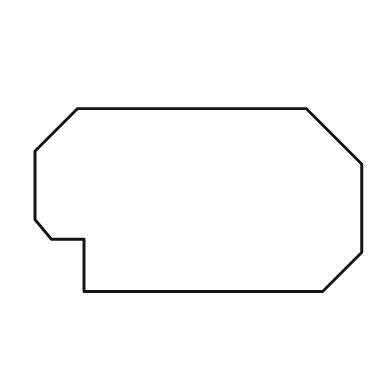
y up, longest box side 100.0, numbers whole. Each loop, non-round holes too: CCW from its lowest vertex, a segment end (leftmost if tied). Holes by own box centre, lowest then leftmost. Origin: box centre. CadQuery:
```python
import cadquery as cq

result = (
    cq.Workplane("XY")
    .moveTo(-35.0, -28.0)
    .lineTo(38.0, -28.0)
    .lineTo(50.0, -16.0)
    .lineTo(50.0, 11.0)
    .lineTo(33.0, 28.0)
    .lineTo(-37.0, 28.0)
    .lineTo(-50.0, 15.0)
    .lineTo(-50.0, -6.0)
    .lineTo(-45.0, -12.0)
    .lineTo(-35.0, -12.0)
    .close()
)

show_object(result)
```